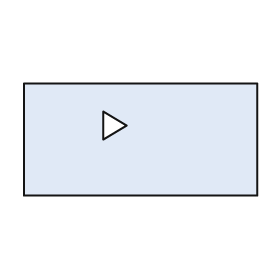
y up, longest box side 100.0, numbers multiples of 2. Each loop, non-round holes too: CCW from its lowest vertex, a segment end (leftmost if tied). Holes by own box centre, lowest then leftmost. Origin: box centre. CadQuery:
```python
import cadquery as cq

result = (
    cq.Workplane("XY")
    .moveTo(-50.0, -24.0)
    .lineTo(50.0, -24.0)
    .lineTo(50.0, 24.0)
    .lineTo(-50.0, 24.0)
    .close()
    .moveTo(-16.0, 0.0)
    .lineTo(-6.0, 6.0)
    .lineTo(-16.0, 12.0)
    .close()
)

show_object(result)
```